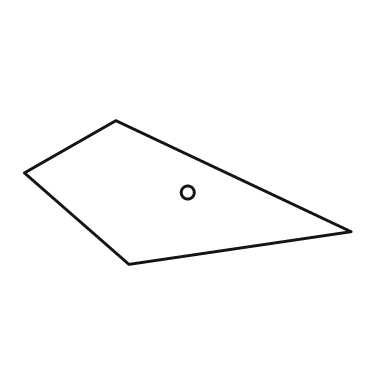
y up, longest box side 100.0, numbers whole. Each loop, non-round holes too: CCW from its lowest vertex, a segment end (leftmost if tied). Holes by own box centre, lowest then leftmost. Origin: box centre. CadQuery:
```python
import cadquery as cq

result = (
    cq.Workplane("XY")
    .moveTo(-18.0, -22.0)
    .lineTo(50.0, -12.0)
    .lineTo(-22.0, 22.0)
    .lineTo(-50.0, 6.0)
    .close()
    .moveTo(0.0, 0.0)
    .circle(2.0)
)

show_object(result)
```